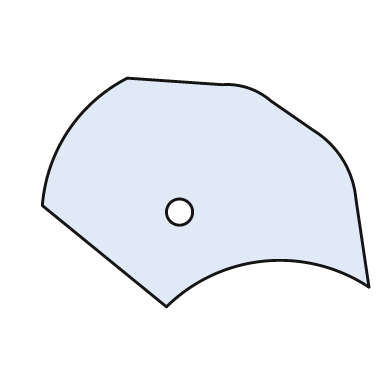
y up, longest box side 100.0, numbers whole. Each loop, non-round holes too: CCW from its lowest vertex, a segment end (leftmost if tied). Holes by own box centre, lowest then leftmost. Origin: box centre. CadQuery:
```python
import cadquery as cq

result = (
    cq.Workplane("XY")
    .moveTo(-12.0, -35.0)
    .threePointArc((18.0, -21.0), (50.0, -29.0))
    .lineTo(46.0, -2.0)
    .threePointArc((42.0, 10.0), (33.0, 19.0))
    .lineTo(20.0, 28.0)
    .threePointArc((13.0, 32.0), (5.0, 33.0))
    .lineTo(-24.0, 35.0)
    .threePointArc((-42.0, 19.0), (-50.0, -4.0))
    .close()
    .moveTo(-8.0, -6.0)
    .circle(4.0)
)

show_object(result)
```